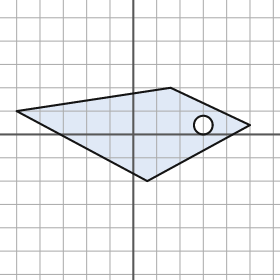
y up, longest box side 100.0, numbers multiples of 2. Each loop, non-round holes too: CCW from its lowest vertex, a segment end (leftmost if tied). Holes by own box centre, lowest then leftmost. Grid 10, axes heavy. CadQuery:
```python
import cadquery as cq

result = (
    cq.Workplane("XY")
    .moveTo(6.0, -20.0)
    .lineTo(50.0, 4.0)
    .lineTo(16.0, 20.0)
    .lineTo(-50.0, 10.0)
    .close()
    .moveTo(30.0, 4.0)
    .circle(4.0)
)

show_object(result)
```